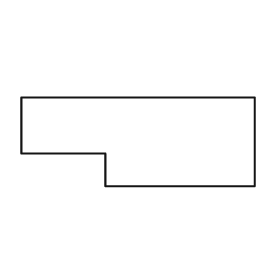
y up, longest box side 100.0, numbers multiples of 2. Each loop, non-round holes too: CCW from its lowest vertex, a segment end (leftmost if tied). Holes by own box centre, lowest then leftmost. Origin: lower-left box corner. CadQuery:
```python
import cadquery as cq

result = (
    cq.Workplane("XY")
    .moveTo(36.0, 0.0)
    .lineTo(100.0, 0.0)
    .lineTo(100.0, 38.0)
    .lineTo(0.0, 38.0)
    .lineTo(0.0, 14.0)
    .lineTo(36.0, 14.0)
    .close()
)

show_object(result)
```